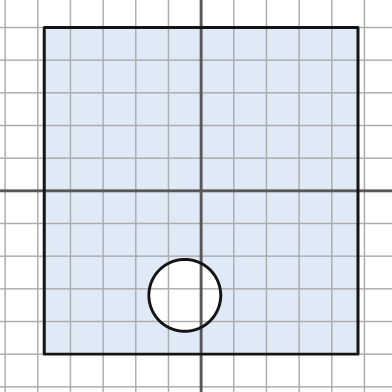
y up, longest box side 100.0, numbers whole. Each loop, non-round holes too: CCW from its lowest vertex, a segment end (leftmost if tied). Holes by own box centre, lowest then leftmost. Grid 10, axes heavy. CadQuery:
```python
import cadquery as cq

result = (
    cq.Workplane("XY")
    .moveTo(-48.0, -50.0)
    .lineTo(48.0, -50.0)
    .lineTo(48.0, 50.0)
    .lineTo(-48.0, 50.0)
    .close()
    .moveTo(-5.0, -32.0)
    .circle(11.0)
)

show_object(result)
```